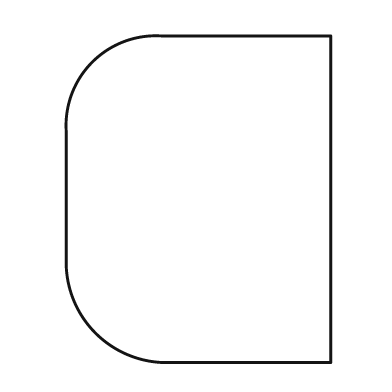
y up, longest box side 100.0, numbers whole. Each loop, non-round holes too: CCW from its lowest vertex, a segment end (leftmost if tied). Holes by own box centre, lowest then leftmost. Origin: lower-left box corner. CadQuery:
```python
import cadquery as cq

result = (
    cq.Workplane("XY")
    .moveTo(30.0, 0.0)
    .lineTo(81.0, 0.0)
    .lineTo(81.0, 100.0)
    .lineTo(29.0, 100.0)
    .threePointArc((8.0, 92.0), (0.0, 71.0))
    .lineTo(0.0, 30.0)
    .threePointArc((9.0, 9.0), (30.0, 0.0))
    .close()
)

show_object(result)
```